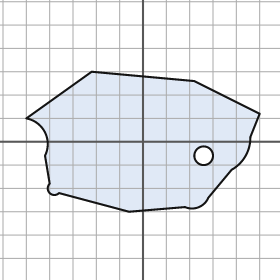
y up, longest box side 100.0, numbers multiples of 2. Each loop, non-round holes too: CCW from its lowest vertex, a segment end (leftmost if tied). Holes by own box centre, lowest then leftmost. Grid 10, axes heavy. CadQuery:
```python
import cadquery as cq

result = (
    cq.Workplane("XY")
    .moveTo(-6.0, -30.0)
    .lineTo(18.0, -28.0)
    .threePointArc((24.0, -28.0), (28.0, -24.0))
    .lineTo(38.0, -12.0)
    .threePointArc((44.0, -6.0), (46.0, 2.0))
    .lineTo(50.0, 12.0)
    .lineTo(22.0, 26.0)
    .lineTo(-22.0, 30.0)
    .lineTo(-50.0, 10.0)
    .threePointArc((-42.0, 4.0), (-42.0, -6.0))
    .lineTo(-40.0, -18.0)
    .threePointArc((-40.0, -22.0), (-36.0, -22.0))
    .close()
    .moveTo(26.0, -6.0)
    .circle(4.0)
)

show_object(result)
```